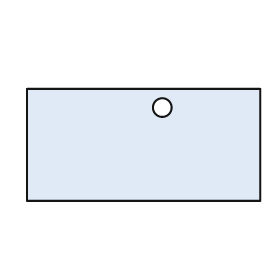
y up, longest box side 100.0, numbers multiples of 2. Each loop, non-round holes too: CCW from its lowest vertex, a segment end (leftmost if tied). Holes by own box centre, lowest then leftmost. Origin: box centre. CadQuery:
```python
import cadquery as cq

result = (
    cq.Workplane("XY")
    .moveTo(-50.0, -24.0)
    .lineTo(50.0, -24.0)
    .lineTo(50.0, 24.0)
    .lineTo(-50.0, 24.0)
    .close()
    .moveTo(8.0, 16.0)
    .circle(4.0)
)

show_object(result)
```